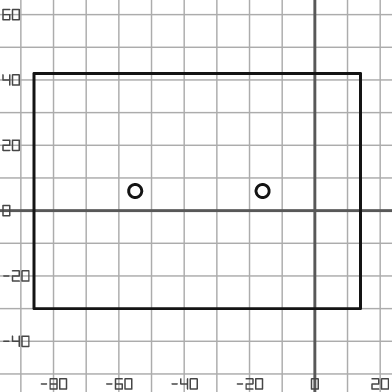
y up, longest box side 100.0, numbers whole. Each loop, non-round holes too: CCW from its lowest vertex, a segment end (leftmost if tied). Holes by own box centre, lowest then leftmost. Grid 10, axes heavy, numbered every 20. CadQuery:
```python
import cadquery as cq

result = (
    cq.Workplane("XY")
    .moveTo(-86.0, -30.0)
    .lineTo(14.0, -30.0)
    .lineTo(14.0, 42.0)
    .lineTo(-86.0, 42.0)
    .close()
    .moveTo(-55.0, 6.0)
    .circle(2.0)
    .moveTo(-16.0, 6.0)
    .circle(2.0)
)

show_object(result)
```